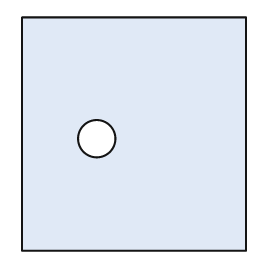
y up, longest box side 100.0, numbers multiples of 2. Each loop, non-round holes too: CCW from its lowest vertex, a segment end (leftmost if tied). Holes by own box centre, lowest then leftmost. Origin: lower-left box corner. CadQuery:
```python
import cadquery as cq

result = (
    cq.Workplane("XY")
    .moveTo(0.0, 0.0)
    .lineTo(96.0, 0.0)
    .lineTo(96.0, 100.0)
    .lineTo(0.0, 100.0)
    .close()
    .moveTo(32.0, 48.0)
    .circle(8.0)
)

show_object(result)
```